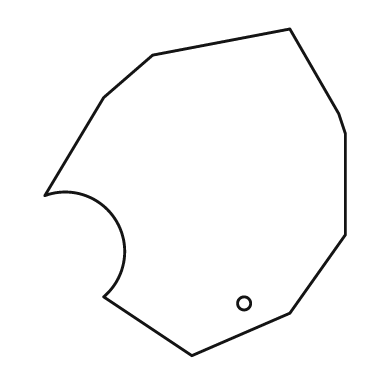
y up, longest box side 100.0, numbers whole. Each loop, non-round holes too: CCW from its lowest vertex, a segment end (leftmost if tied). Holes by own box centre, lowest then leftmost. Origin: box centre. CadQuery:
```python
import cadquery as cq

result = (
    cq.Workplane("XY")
    .moveTo(-1.0, -50.0)
    .lineTo(29.0, -37.0)
    .lineTo(46.0, -13.0)
    .lineTo(46.0, 18.0)
    .lineTo(44.0, 24.0)
    .lineTo(29.0, 50.0)
    .lineTo(-13.0, 42.0)
    .lineTo(-28.0, 29.0)
    .lineTo(-46.0, -1.0)
    .threePointArc((-24.0, -9.0), (-28.0, -32.0))
    .close()
    .moveTo(15.0, -34.0)
    .circle(2.0)
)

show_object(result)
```